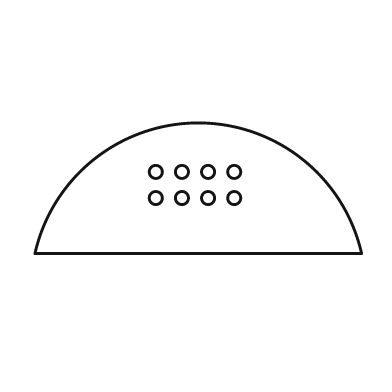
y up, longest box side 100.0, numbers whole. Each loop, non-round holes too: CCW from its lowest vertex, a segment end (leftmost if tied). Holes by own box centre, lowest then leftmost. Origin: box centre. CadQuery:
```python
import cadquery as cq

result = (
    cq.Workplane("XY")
    .moveTo(-50.0, -20.0)
    .lineTo(50.0, -20.0)
    .threePointArc((0.0, 20.0), (-50.0, -20.0))
    .close()
    .moveTo(-13.0, -3.0)
    .circle(2.0)
    .moveTo(-5.0, -3.0)
    .circle(2.0)
    .moveTo(3.0, -3.0)
    .circle(2.0)
    .moveTo(11.0, -3.0)
    .circle(2.0)
    .moveTo(-13.0, 5.0)
    .circle(2.0)
    .moveTo(-5.0, 5.0)
    .circle(2.0)
    .moveTo(3.0, 5.0)
    .circle(2.0)
    .moveTo(11.0, 5.0)
    .circle(2.0)
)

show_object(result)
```